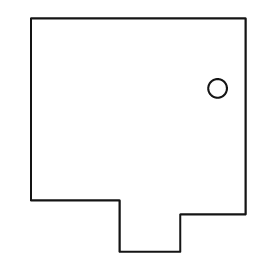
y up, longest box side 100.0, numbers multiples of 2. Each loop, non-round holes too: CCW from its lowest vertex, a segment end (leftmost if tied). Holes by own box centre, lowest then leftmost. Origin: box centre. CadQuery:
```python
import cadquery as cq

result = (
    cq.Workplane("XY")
    .moveTo(-8.0, -50.0)
    .lineTo(18.0, -50.0)
    .lineTo(18.0, -34.0)
    .lineTo(46.0, -34.0)
    .lineTo(46.0, 50.0)
    .lineTo(-46.0, 50.0)
    .lineTo(-46.0, -28.0)
    .lineTo(-8.0, -28.0)
    .close()
    .moveTo(34.0, 20.0)
    .circle(4.0)
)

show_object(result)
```